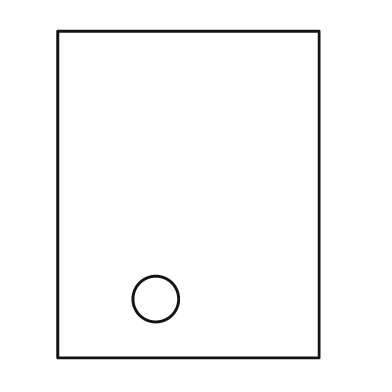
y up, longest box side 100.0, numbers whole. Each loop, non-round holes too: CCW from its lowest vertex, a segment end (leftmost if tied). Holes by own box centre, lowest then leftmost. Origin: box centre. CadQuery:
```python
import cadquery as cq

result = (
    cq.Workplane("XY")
    .moveTo(-40.0, -50.0)
    .lineTo(40.0, -50.0)
    .lineTo(40.0, 50.0)
    .lineTo(-40.0, 50.0)
    .close()
    .moveTo(-10.0, -32.0)
    .circle(7.0)
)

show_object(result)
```